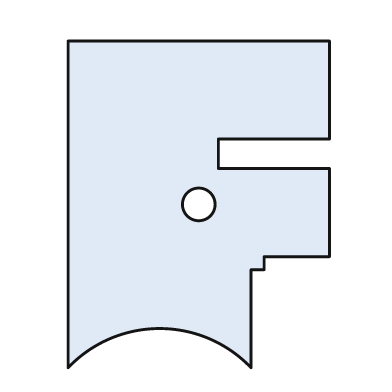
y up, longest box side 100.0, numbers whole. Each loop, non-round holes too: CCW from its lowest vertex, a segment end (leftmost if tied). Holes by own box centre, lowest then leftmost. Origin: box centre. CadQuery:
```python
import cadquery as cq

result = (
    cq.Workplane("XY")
    .moveTo(-40.0, -50.0)
    .threePointArc((-12.0, -38.0), (16.0, -50.0))
    .lineTo(16.0, -20.0)
    .lineTo(20.0, -20.0)
    .lineTo(20.0, -16.0)
    .lineTo(40.0, -16.0)
    .lineTo(40.0, 11.0)
    .lineTo(6.0, 11.0)
    .lineTo(6.0, 20.0)
    .lineTo(40.0, 20.0)
    .lineTo(40.0, 50.0)
    .lineTo(-40.0, 50.0)
    .close()
    .moveTo(0.0, 0.0)
    .circle(5.0)
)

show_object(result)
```